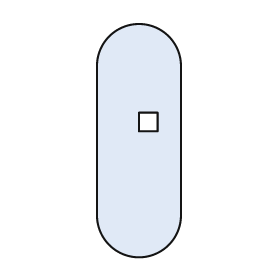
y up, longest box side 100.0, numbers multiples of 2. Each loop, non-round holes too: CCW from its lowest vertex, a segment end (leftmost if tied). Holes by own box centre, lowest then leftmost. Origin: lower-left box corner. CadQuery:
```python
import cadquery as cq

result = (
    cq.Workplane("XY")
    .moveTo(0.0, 18.0)
    .threePointArc((18.0, 0.0), (36.0, 18.0))
    .lineTo(36.0, 82.0)
    .threePointArc((18.0, 100.0), (0.0, 82.0))
    .close()
    .moveTo(18.0, 54.0)
    .lineTo(26.0, 54.0)
    .lineTo(26.0, 62.0)
    .lineTo(18.0, 62.0)
    .close()
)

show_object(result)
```